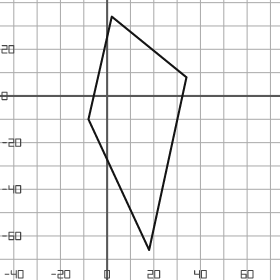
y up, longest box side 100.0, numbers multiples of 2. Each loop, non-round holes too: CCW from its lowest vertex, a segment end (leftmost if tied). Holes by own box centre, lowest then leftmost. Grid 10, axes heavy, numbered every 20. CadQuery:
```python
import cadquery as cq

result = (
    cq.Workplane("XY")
    .moveTo(18.0, -66.0)
    .lineTo(34.0, 8.0)
    .lineTo(2.0, 34.0)
    .lineTo(-8.0, -10.0)
    .close()
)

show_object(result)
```